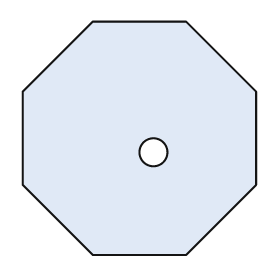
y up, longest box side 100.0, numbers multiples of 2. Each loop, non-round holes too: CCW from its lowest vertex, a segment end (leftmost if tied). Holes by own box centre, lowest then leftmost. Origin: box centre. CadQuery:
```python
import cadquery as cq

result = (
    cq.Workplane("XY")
    .moveTo(-20.0, -50.0)
    .lineTo(20.0, -50.0)
    .lineTo(50.0, -20.0)
    .lineTo(50.0, 20.0)
    .lineTo(20.0, 50.0)
    .lineTo(-20.0, 50.0)
    .lineTo(-50.0, 20.0)
    .lineTo(-50.0, -20.0)
    .close()
    .moveTo(6.0, -6.0)
    .circle(6.0)
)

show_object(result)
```